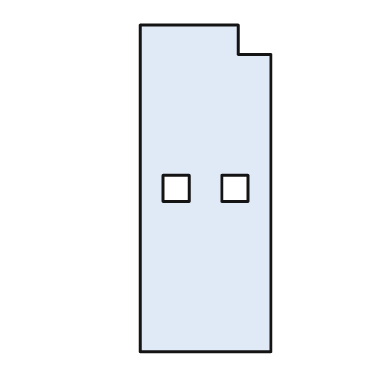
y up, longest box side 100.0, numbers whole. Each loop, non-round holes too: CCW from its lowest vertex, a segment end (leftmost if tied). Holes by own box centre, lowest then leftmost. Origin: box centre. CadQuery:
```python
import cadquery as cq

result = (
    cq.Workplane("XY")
    .moveTo(-20.0, -50.0)
    .lineTo(20.0, -50.0)
    .lineTo(20.0, 41.0)
    .lineTo(10.0, 41.0)
    .lineTo(10.0, 50.0)
    .lineTo(-20.0, 50.0)
    .close()
    .moveTo(-13.0, -4.0)
    .lineTo(-5.0, -4.0)
    .lineTo(-5.0, 4.0)
    .lineTo(-13.0, 4.0)
    .close()
    .moveTo(5.0, -4.0)
    .lineTo(13.0, -4.0)
    .lineTo(13.0, 4.0)
    .lineTo(5.0, 4.0)
    .close()
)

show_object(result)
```